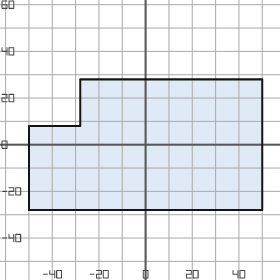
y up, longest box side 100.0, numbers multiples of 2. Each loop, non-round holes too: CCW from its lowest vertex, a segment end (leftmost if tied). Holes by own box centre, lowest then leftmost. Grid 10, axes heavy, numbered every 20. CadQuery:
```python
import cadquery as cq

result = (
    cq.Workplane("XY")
    .moveTo(-50.0, -28.0)
    .lineTo(50.0, -28.0)
    .lineTo(50.0, 28.0)
    .lineTo(-28.0, 28.0)
    .lineTo(-28.0, 8.0)
    .lineTo(-50.0, 8.0)
    .close()
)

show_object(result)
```